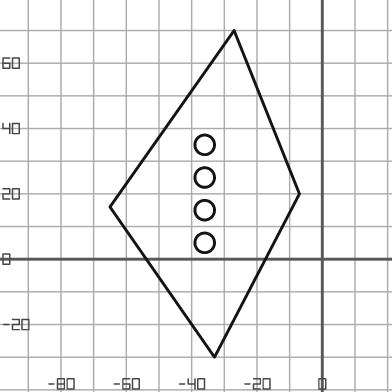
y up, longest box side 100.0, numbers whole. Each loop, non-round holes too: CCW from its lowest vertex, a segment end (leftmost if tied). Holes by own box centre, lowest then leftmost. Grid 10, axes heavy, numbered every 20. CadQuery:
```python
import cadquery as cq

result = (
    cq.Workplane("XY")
    .moveTo(-33.0, -30.0)
    .lineTo(-7.0, 20.0)
    .lineTo(-27.0, 70.0)
    .lineTo(-65.0, 16.0)
    .close()
    .moveTo(-36.0, 5.0)
    .circle(3.0)
    .moveTo(-36.0, 15.0)
    .circle(3.0)
    .moveTo(-36.0, 25.0)
    .circle(3.0)
    .moveTo(-36.0, 35.0)
    .circle(3.0)
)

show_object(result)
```